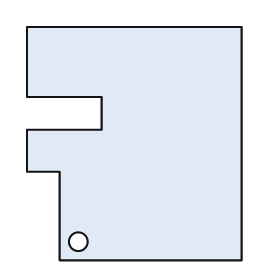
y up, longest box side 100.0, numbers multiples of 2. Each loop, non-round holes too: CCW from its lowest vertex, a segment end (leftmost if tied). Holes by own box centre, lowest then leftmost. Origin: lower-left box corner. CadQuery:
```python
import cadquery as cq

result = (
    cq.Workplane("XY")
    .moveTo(14.0, 0.0)
    .lineTo(92.0, 0.0)
    .lineTo(92.0, 100.0)
    .lineTo(0.0, 100.0)
    .lineTo(0.0, 70.0)
    .lineTo(32.0, 70.0)
    .lineTo(32.0, 56.0)
    .lineTo(0.0, 56.0)
    .lineTo(0.0, 38.0)
    .lineTo(14.0, 38.0)
    .close()
    .moveTo(22.0, 8.0)
    .circle(4.0)
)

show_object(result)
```